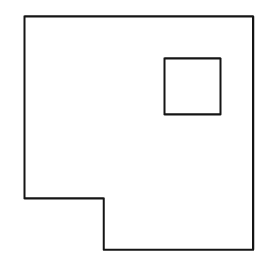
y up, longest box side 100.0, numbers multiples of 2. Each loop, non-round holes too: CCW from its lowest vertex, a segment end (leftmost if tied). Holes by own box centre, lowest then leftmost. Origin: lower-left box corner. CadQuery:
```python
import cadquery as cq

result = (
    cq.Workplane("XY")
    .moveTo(34.0, 0.0)
    .lineTo(98.0, 0.0)
    .lineTo(98.0, 100.0)
    .lineTo(0.0, 100.0)
    .lineTo(0.0, 22.0)
    .lineTo(34.0, 22.0)
    .close()
    .moveTo(60.0, 58.0)
    .lineTo(84.0, 58.0)
    .lineTo(84.0, 82.0)
    .lineTo(60.0, 82.0)
    .close()
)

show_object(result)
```